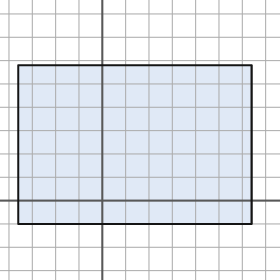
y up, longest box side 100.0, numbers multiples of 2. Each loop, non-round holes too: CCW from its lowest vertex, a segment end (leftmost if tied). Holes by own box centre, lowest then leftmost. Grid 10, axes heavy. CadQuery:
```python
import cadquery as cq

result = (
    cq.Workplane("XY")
    .moveTo(-36.0, -10.0)
    .lineTo(64.0, -10.0)
    .lineTo(64.0, 58.0)
    .lineTo(-36.0, 58.0)
    .close()
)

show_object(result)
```